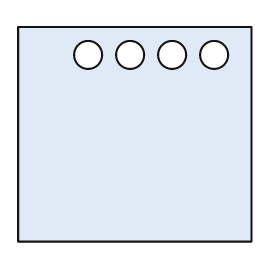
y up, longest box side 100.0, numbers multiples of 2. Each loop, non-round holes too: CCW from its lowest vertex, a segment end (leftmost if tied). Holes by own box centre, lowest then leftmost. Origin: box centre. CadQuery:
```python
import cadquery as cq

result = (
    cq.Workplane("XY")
    .moveTo(-50.0, -46.0)
    .lineTo(50.0, -46.0)
    .lineTo(50.0, 46.0)
    .lineTo(-50.0, 46.0)
    .close()
    .moveTo(-20.0, 34.0)
    .circle(6.0)
    .moveTo(-2.0, 34.0)
    .circle(6.0)
    .moveTo(16.0, 34.0)
    .circle(6.0)
    .moveTo(34.0, 34.0)
    .circle(6.0)
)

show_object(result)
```